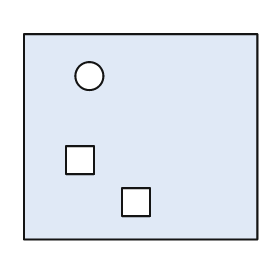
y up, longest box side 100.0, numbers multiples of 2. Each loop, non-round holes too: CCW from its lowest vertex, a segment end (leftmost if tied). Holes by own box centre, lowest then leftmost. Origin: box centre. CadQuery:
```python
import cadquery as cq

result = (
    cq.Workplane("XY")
    .moveTo(-50.0, -44.0)
    .lineTo(50.0, -44.0)
    .lineTo(50.0, 44.0)
    .lineTo(-50.0, 44.0)
    .close()
    .moveTo(-8.0, -34.0)
    .lineTo(4.0, -34.0)
    .lineTo(4.0, -22.0)
    .lineTo(-8.0, -22.0)
    .close()
    .moveTo(-32.0, -16.0)
    .lineTo(-20.0, -16.0)
    .lineTo(-20.0, -4.0)
    .lineTo(-32.0, -4.0)
    .close()
    .moveTo(-22.0, 26.0)
    .circle(6.0)
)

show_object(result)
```